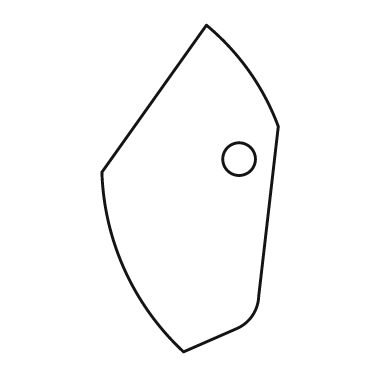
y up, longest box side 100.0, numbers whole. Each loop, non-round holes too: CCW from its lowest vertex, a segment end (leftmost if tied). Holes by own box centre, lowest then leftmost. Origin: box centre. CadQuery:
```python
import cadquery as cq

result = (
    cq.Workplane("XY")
    .moveTo(-2.0, -50.0)
    .lineTo(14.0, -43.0)
    .threePointArc((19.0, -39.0), (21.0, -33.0))
    .lineTo(27.0, 19.0)
    .threePointArc((18.0, 36.0), (5.0, 50.0))
    .lineTo(-27.0, 5.0)
    .threePointArc((-20.0, -25.0), (-2.0, -50.0))
    .close()
    .moveTo(15.0, 9.0)
    .circle(5.0)
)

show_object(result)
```